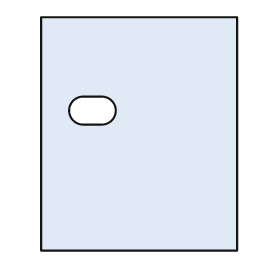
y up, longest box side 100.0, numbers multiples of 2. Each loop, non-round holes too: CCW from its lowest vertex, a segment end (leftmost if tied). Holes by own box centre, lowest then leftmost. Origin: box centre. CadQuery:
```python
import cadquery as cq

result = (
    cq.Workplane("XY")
    .moveTo(-42.0, -50.0)
    .lineTo(42.0, -50.0)
    .lineTo(42.0, 50.0)
    .lineTo(-42.0, 50.0)
    .close()
    .moveTo(-24.0, 4.0)
    .lineTo(-16.0, 4.0)
    .threePointArc((-10.0, 10.0), (-16.0, 16.0))
    .lineTo(-24.0, 16.0)
    .threePointArc((-30.0, 10.0), (-24.0, 4.0))
    .close()
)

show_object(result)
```